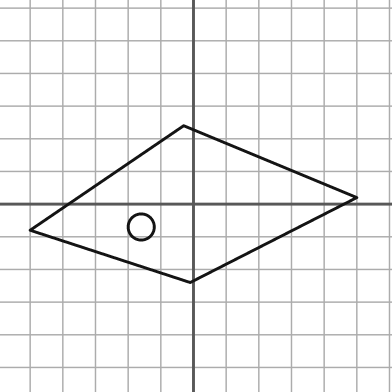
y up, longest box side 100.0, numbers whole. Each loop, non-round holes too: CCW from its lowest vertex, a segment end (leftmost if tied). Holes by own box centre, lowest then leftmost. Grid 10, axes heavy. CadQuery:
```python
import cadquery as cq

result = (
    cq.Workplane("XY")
    .moveTo(-1.0, -24.0)
    .lineTo(50.0, 2.0)
    .lineTo(-3.0, 24.0)
    .lineTo(-50.0, -8.0)
    .close()
    .moveTo(-16.0, -7.0)
    .circle(4.0)
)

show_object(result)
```